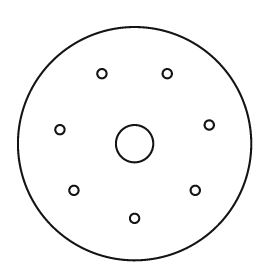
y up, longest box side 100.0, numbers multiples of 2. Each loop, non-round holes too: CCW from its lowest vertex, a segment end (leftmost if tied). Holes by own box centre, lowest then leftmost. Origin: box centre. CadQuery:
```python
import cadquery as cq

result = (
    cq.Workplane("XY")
    .moveTo(0.0, 0.0)
    .circle(50.0)
    .moveTo(0.0, -32.0)
    .circle(2.0)
    .moveTo(-26.0, -20.0)
    .circle(2.0)
    .moveTo(26.0, -20.0)
    .circle(2.0)
    .moveTo(0.0, 0.0)
    .circle(8.0)
    .moveTo(-32.0, 6.0)
    .circle(2.0)
    .moveTo(32.0, 8.0)
    .circle(2.0)
    .moveTo(-14.0, 30.0)
    .circle(2.0)
    .moveTo(14.0, 30.0)
    .circle(2.0)
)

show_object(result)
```